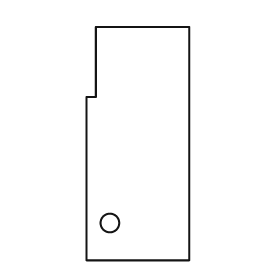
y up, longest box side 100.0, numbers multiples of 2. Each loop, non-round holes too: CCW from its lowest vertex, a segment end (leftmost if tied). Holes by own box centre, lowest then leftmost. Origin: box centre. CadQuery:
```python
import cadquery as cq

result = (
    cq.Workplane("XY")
    .moveTo(-22.0, -50.0)
    .lineTo(22.0, -50.0)
    .lineTo(22.0, 50.0)
    .lineTo(-18.0, 50.0)
    .lineTo(-18.0, 20.0)
    .lineTo(-22.0, 20.0)
    .close()
    .moveTo(-12.0, -34.0)
    .circle(4.0)
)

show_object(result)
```